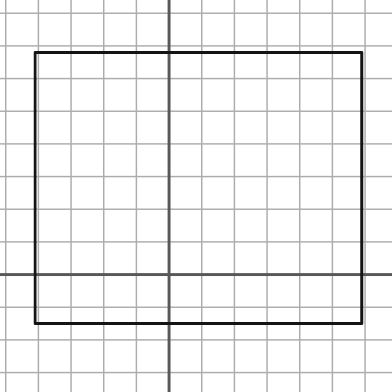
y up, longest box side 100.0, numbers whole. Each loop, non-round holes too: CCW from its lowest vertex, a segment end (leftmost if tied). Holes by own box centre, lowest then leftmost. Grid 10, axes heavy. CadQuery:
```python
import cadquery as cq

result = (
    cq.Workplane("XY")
    .moveTo(-41.0, -15.0)
    .lineTo(59.0, -15.0)
    .lineTo(59.0, 68.0)
    .lineTo(-41.0, 68.0)
    .close()
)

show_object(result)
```